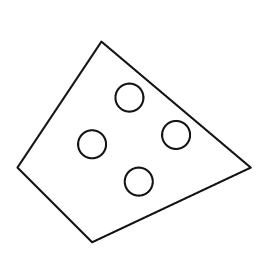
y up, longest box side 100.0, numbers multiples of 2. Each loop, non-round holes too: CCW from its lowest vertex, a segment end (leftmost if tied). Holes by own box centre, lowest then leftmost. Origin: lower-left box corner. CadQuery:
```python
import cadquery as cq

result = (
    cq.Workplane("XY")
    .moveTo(32.0, 0.0)
    .lineTo(100.0, 32.0)
    .lineTo(36.0, 86.0)
    .lineTo(0.0, 32.0)
    .close()
    .moveTo(52.0, 26.0)
    .circle(6.0)
    .moveTo(32.0, 42.0)
    .circle(6.0)
    .moveTo(68.0, 46.0)
    .circle(6.0)
    .moveTo(48.0, 62.0)
    .circle(6.0)
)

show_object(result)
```